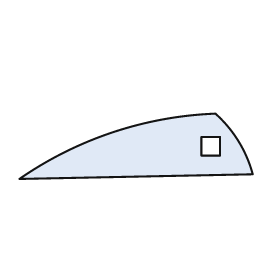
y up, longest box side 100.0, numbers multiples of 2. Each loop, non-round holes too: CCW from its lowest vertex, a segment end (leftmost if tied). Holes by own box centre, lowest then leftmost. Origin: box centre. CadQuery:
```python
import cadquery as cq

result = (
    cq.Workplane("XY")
    .moveTo(-50.0, -14.0)
    .lineTo(50.0, -12.0)
    .threePointArc((44.0, 2.0), (34.0, 14.0))
    .threePointArc((-10.0, 6.0), (-50.0, -14.0))
    .close()
    .moveTo(28.0, -4.0)
    .lineTo(36.0, -4.0)
    .lineTo(36.0, 4.0)
    .lineTo(28.0, 4.0)
    .close()
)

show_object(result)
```